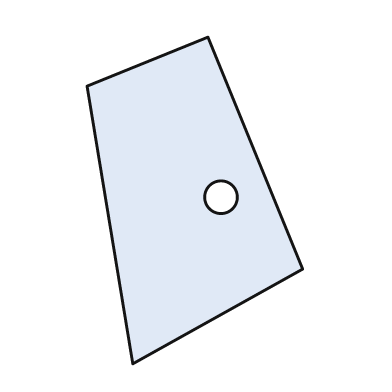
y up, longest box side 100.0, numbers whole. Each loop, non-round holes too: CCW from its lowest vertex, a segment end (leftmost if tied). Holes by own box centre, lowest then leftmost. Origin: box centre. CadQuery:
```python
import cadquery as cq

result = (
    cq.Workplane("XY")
    .moveTo(-19.0, -50.0)
    .lineTo(33.0, -21.0)
    .lineTo(4.0, 50.0)
    .lineTo(-33.0, 35.0)
    .close()
    .moveTo(8.0, 1.0)
    .circle(5.0)
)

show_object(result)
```